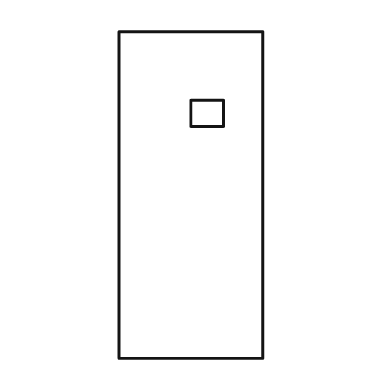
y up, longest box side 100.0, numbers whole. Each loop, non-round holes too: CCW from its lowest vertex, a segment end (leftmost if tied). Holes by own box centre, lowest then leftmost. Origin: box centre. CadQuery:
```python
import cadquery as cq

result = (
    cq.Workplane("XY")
    .moveTo(-22.0, -50.0)
    .lineTo(22.0, -50.0)
    .lineTo(22.0, 50.0)
    .lineTo(-22.0, 50.0)
    .close()
    .moveTo(0.0, 21.0)
    .lineTo(10.0, 21.0)
    .lineTo(10.0, 29.0)
    .lineTo(0.0, 29.0)
    .close()
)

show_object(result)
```